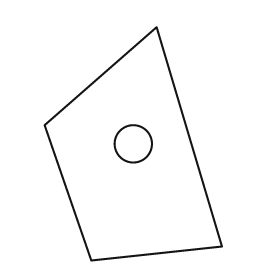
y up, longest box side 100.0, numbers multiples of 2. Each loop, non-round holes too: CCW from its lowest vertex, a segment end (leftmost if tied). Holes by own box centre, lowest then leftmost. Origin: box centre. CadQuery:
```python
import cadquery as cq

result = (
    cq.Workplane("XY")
    .moveTo(-18.0, -50.0)
    .lineTo(38.0, -44.0)
    .lineTo(10.0, 50.0)
    .lineTo(-38.0, 8.0)
    .close()
    .moveTo(0.0, 0.0)
    .circle(8.0)
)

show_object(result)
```